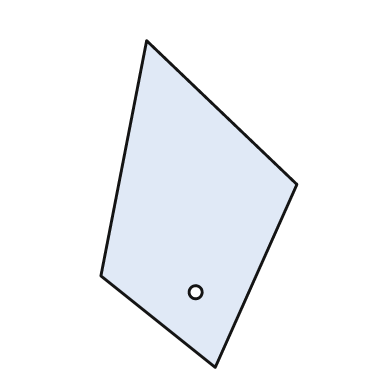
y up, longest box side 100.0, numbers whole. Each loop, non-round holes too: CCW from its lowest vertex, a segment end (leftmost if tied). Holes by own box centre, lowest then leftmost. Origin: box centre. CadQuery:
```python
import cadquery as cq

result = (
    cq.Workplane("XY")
    .moveTo(5.0, -50.0)
    .lineTo(30.0, 6.0)
    .lineTo(-16.0, 50.0)
    .lineTo(-30.0, -22.0)
    .close()
    .moveTo(-1.0, -27.0)
    .circle(2.0)
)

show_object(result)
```